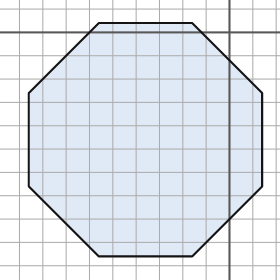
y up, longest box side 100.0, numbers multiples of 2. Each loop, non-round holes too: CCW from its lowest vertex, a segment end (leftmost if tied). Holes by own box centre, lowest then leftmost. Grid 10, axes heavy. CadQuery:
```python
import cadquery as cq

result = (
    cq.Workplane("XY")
    .moveTo(-56.0, -96.0)
    .lineTo(-16.0, -96.0)
    .lineTo(14.0, -66.0)
    .lineTo(14.0, -26.0)
    .lineTo(-16.0, 4.0)
    .lineTo(-56.0, 4.0)
    .lineTo(-86.0, -26.0)
    .lineTo(-86.0, -66.0)
    .close()
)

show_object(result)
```